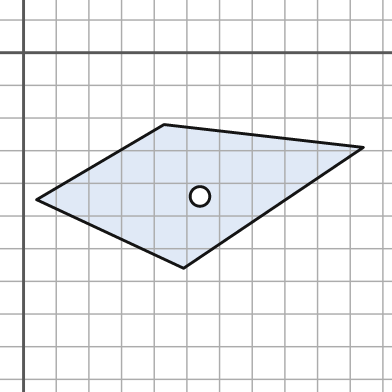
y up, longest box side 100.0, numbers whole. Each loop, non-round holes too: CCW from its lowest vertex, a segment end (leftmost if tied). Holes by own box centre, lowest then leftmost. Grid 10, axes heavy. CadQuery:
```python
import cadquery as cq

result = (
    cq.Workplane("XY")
    .moveTo(49.0, -66.0)
    .lineTo(104.0, -29.0)
    .lineTo(43.0, -22.0)
    .lineTo(4.0, -45.0)
    .close()
    .moveTo(54.0, -44.0)
    .circle(3.0)
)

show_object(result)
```